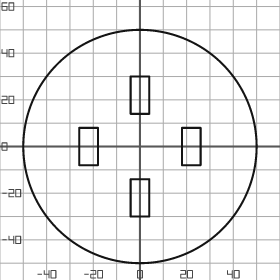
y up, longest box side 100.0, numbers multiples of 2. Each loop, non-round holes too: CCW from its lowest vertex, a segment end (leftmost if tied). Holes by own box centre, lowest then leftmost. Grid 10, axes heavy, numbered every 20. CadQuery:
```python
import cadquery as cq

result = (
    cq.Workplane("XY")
    .moveTo(0.0, 0.0)
    .circle(50.0)
    .moveTo(-4.0, -30.0)
    .lineTo(4.0, -30.0)
    .lineTo(4.0, -14.0)
    .lineTo(-4.0, -14.0)
    .close()
    .moveTo(-26.0, -8.0)
    .lineTo(-18.0, -8.0)
    .lineTo(-18.0, 8.0)
    .lineTo(-26.0, 8.0)
    .close()
    .moveTo(18.0, -8.0)
    .lineTo(26.0, -8.0)
    .lineTo(26.0, 8.0)
    .lineTo(18.0, 8.0)
    .close()
    .moveTo(-4.0, 14.0)
    .lineTo(4.0, 14.0)
    .lineTo(4.0, 30.0)
    .lineTo(-4.0, 30.0)
    .close()
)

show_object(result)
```